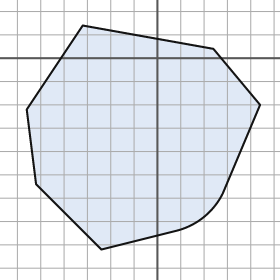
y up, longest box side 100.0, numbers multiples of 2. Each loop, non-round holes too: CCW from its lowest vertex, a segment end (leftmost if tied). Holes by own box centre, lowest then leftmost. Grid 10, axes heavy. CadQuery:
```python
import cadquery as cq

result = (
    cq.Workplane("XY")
    .moveTo(-24.0, -82.0)
    .lineTo(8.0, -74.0)
    .threePointArc((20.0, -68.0), (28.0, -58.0))
    .lineTo(44.0, -20.0)
    .lineTo(24.0, 4.0)
    .lineTo(-32.0, 14.0)
    .lineTo(-56.0, -22.0)
    .lineTo(-52.0, -54.0)
    .close()
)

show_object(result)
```